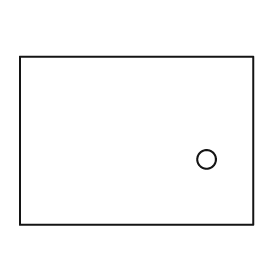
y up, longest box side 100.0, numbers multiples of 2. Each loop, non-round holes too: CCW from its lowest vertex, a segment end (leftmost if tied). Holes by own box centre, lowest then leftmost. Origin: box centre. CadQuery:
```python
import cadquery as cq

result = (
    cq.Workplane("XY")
    .moveTo(-50.0, -36.0)
    .lineTo(50.0, -36.0)
    .lineTo(50.0, 36.0)
    .lineTo(-50.0, 36.0)
    .close()
    .moveTo(30.0, -8.0)
    .circle(4.0)
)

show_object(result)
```